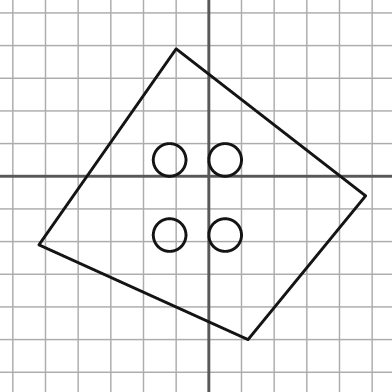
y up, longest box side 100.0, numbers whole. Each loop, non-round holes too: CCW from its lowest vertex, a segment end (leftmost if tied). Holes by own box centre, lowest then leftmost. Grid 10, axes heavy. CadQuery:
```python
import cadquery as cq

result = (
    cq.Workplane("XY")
    .moveTo(12.0, -50.0)
    .lineTo(48.0, -6.0)
    .lineTo(-10.0, 39.0)
    .lineTo(-52.0, -21.0)
    .close()
    .moveTo(-12.0, -18.0)
    .circle(5.0)
    .moveTo(5.0, -18.0)
    .circle(5.0)
    .moveTo(-12.0, 5.0)
    .circle(5.0)
    .moveTo(5.0, 5.0)
    .circle(5.0)
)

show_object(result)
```